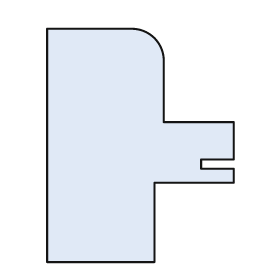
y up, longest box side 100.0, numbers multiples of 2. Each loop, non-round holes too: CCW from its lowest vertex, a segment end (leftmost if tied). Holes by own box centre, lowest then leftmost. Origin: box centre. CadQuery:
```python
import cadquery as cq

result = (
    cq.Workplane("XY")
    .moveTo(-40.0, -50.0)
    .lineTo(6.0, -50.0)
    .lineTo(6.0, -16.0)
    .lineTo(40.0, -16.0)
    .lineTo(40.0, -10.0)
    .lineTo(26.0, -10.0)
    .lineTo(26.0, -6.0)
    .lineTo(40.0, -6.0)
    .lineTo(40.0, 10.0)
    .lineTo(10.0, 10.0)
    .lineTo(10.0, 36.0)
    .threePointArc((6.0, 46.0), (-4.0, 50.0))
    .lineTo(-40.0, 50.0)
    .close()
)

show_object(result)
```